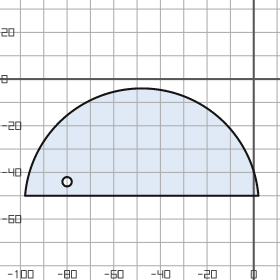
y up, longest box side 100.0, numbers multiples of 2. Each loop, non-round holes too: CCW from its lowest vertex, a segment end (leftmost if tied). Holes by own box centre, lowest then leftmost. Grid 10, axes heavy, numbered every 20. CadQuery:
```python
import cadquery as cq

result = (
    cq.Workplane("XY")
    .moveTo(-98.0, -50.0)
    .lineTo(2.0, -50.0)
    .threePointArc((-48.0, -4.0), (-98.0, -50.0))
    .close()
    .moveTo(-80.0, -44.0)
    .circle(2.0)
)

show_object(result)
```